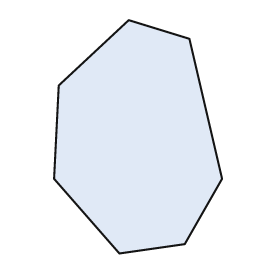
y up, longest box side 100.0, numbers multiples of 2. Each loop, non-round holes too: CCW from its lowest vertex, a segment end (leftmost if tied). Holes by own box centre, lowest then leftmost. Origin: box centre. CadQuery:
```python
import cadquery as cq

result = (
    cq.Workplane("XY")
    .moveTo(-8.0, -50.0)
    .lineTo(20.0, -46.0)
    .lineTo(36.0, -18.0)
    .lineTo(22.0, 42.0)
    .lineTo(-4.0, 50.0)
    .lineTo(-34.0, 22.0)
    .lineTo(-36.0, -18.0)
    .close()
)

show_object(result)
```